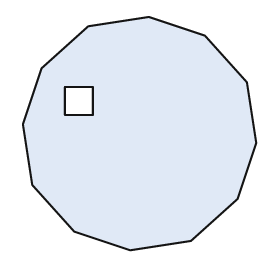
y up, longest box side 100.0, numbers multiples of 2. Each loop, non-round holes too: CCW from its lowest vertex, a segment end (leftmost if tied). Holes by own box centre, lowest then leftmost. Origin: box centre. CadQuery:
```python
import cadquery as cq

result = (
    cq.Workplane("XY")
    .moveTo(-4.0, -50.0)
    .lineTo(22.0, -46.0)
    .lineTo(42.0, -28.0)
    .lineTo(50.0, -4.0)
    .lineTo(46.0, 22.0)
    .lineTo(28.0, 42.0)
    .lineTo(4.0, 50.0)
    .lineTo(-22.0, 46.0)
    .lineTo(-42.0, 28.0)
    .lineTo(-50.0, 4.0)
    .lineTo(-46.0, -22.0)
    .lineTo(-28.0, -42.0)
    .close()
    .moveTo(-32.0, 8.0)
    .lineTo(-20.0, 8.0)
    .lineTo(-20.0, 20.0)
    .lineTo(-32.0, 20.0)
    .close()
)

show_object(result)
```